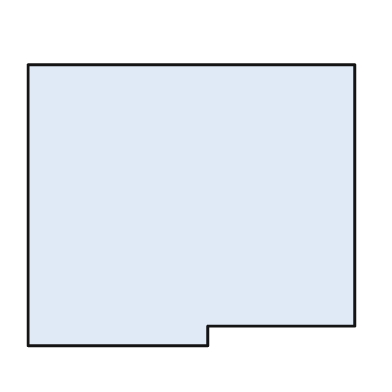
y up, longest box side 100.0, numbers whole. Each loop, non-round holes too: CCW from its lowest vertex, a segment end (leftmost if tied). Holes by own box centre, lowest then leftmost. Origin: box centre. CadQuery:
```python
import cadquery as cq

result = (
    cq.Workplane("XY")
    .moveTo(-50.0, -43.0)
    .lineTo(5.0, -43.0)
    .lineTo(5.0, -37.0)
    .lineTo(50.0, -37.0)
    .lineTo(50.0, 43.0)
    .lineTo(-50.0, 43.0)
    .close()
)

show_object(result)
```